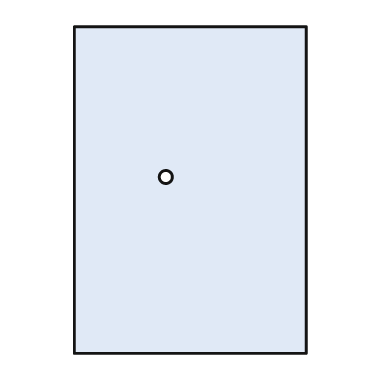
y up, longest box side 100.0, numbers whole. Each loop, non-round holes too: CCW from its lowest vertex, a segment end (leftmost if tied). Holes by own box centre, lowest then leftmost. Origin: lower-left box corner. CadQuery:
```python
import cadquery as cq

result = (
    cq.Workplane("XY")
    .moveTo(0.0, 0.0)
    .lineTo(71.0, 0.0)
    .lineTo(71.0, 100.0)
    .lineTo(0.0, 100.0)
    .close()
    .moveTo(28.0, 54.0)
    .circle(2.0)
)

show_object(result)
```